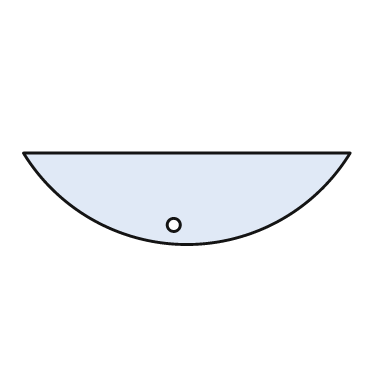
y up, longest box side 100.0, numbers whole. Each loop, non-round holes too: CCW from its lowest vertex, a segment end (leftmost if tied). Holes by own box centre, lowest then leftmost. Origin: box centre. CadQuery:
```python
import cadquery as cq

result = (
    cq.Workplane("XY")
    .moveTo(-50.0, 14.0)
    .threePointArc((0.0, -14.0), (50.0, 14.0))
    .close()
    .moveTo(-4.0, -8.0)
    .circle(2.0)
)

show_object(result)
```